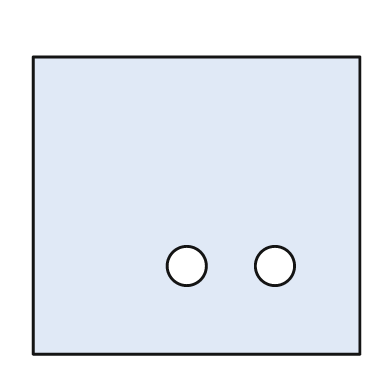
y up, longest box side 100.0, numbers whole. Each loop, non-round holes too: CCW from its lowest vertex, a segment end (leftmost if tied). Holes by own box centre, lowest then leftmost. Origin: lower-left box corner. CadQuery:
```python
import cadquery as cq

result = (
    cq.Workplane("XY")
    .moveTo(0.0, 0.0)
    .lineTo(100.0, 0.0)
    .lineTo(100.0, 91.0)
    .lineTo(0.0, 91.0)
    .close()
    .moveTo(47.0, 27.0)
    .circle(6.0)
    .moveTo(74.0, 27.0)
    .circle(6.0)
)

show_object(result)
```